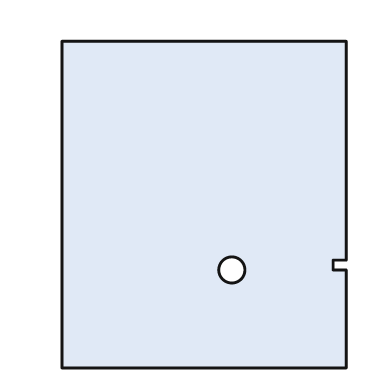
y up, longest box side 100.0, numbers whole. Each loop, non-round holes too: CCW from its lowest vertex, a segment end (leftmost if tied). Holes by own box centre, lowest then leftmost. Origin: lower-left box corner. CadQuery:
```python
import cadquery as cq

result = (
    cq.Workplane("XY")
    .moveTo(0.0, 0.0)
    .lineTo(87.0, 0.0)
    .lineTo(87.0, 30.0)
    .lineTo(83.0, 30.0)
    .lineTo(83.0, 33.0)
    .lineTo(87.0, 33.0)
    .lineTo(87.0, 100.0)
    .lineTo(0.0, 100.0)
    .close()
    .moveTo(52.0, 30.0)
    .circle(4.0)
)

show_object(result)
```